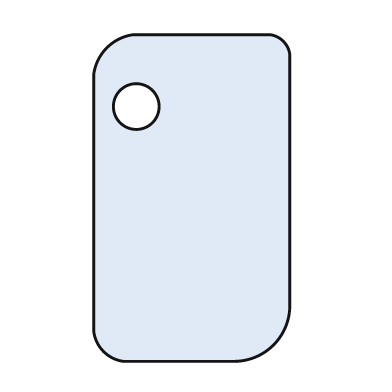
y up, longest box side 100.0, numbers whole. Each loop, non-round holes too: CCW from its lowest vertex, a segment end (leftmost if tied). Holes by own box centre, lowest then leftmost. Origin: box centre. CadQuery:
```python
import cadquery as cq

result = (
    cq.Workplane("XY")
    .moveTo(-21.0, -50.0)
    .lineTo(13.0, -50.0)
    .threePointArc((25.0, -45.0), (30.0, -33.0))
    .lineTo(30.0, 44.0)
    .threePointArc((28.0, 48.0), (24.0, 50.0))
    .lineTo(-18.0, 50.0)
    .threePointArc((-26.0, 46.0), (-30.0, 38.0))
    .lineTo(-30.0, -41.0)
    .threePointArc((-27.0, -47.0), (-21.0, -50.0))
    .close()
    .moveTo(-17.0, 28.0)
    .circle(7.0)
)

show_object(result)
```